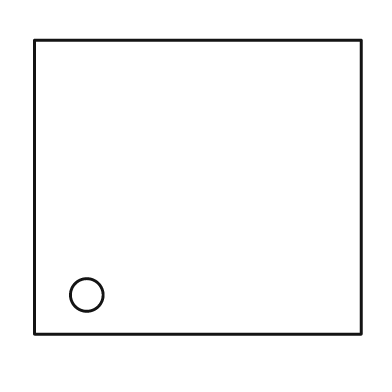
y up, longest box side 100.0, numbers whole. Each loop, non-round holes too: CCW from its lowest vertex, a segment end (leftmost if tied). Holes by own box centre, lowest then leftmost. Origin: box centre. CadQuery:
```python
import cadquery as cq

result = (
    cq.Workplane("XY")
    .moveTo(-50.0, -45.0)
    .lineTo(50.0, -45.0)
    .lineTo(50.0, 45.0)
    .lineTo(-50.0, 45.0)
    .close()
    .moveTo(-34.0, -33.0)
    .circle(5.0)
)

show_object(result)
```